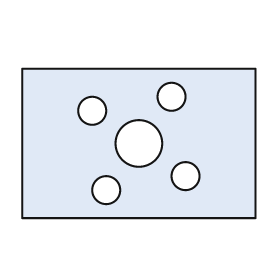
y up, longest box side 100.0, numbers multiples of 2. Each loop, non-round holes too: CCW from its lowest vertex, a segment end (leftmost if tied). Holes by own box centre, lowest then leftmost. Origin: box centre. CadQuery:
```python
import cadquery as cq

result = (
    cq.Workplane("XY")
    .moveTo(-50.0, -32.0)
    .lineTo(50.0, -32.0)
    .lineTo(50.0, 32.0)
    .lineTo(-50.0, 32.0)
    .close()
    .moveTo(-14.0, -20.0)
    .circle(6.0)
    .moveTo(20.0, -14.0)
    .circle(6.0)
    .moveTo(0.0, 0.0)
    .circle(10.0)
    .moveTo(-20.0, 14.0)
    .circle(6.0)
    .moveTo(14.0, 20.0)
    .circle(6.0)
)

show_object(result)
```